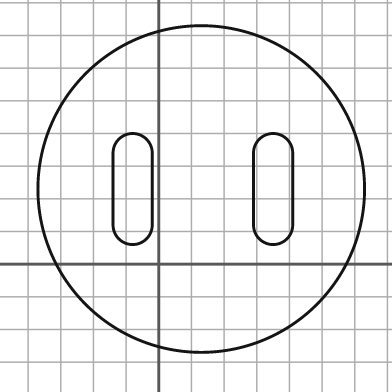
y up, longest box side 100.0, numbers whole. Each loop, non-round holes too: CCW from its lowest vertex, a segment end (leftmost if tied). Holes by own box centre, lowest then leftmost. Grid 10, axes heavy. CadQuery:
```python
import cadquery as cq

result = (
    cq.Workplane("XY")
    .moveTo(13.0, 23.0)
    .circle(50.0)
    .moveTo(-14.0, 12.0)
    .threePointArc((-8.0, 6.0), (-2.0, 12.0))
    .lineTo(-2.0, 34.0)
    .threePointArc((-8.0, 40.0), (-14.0, 34.0))
    .close()
    .moveTo(29.0, 12.0)
    .threePointArc((35.0, 6.0), (41.0, 12.0))
    .lineTo(41.0, 34.0)
    .threePointArc((35.0, 40.0), (29.0, 34.0))
    .close()
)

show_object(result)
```